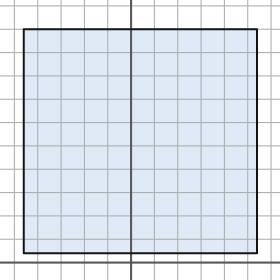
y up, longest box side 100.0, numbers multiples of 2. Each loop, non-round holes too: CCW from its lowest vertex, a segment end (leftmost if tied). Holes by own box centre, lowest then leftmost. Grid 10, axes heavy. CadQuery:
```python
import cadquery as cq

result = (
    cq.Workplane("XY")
    .moveTo(-46.0, 4.0)
    .lineTo(54.0, 4.0)
    .lineTo(54.0, 100.0)
    .lineTo(-46.0, 100.0)
    .close()
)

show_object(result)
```